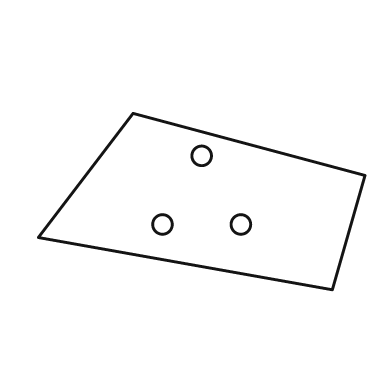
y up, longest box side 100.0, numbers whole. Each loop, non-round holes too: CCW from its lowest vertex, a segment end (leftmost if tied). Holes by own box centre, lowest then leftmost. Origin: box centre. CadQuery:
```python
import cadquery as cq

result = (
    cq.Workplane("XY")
    .moveTo(40.0, -27.0)
    .lineTo(50.0, 8.0)
    .lineTo(-21.0, 27.0)
    .lineTo(-50.0, -11.0)
    .close()
    .moveTo(-12.0, -7.0)
    .circle(3.0)
    .moveTo(12.0, -7.0)
    .circle(3.0)
    .moveTo(0.0, 14.0)
    .circle(3.0)
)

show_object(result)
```